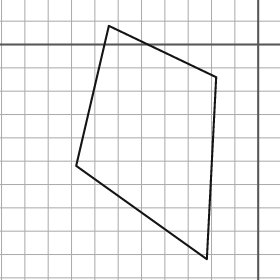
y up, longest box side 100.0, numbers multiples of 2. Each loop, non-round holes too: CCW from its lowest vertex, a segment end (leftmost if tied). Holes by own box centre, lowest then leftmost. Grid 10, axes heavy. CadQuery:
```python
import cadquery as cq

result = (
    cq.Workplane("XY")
    .moveTo(-22.0, -92.0)
    .lineTo(-18.0, -14.0)
    .lineTo(-64.0, 8.0)
    .lineTo(-78.0, -52.0)
    .close()
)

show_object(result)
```